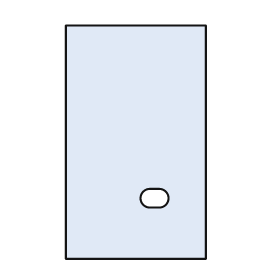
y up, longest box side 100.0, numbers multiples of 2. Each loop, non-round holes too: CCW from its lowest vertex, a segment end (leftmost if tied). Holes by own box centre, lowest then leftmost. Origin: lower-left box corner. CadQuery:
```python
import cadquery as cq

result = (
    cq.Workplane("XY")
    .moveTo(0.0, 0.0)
    .lineTo(60.0, 0.0)
    .lineTo(60.0, 100.0)
    .lineTo(0.0, 100.0)
    .close()
    .moveTo(36.0, 22.0)
    .lineTo(40.0, 22.0)
    .threePointArc((44.0, 26.0), (40.0, 30.0))
    .lineTo(36.0, 30.0)
    .threePointArc((32.0, 26.0), (36.0, 22.0))
    .close()
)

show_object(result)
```